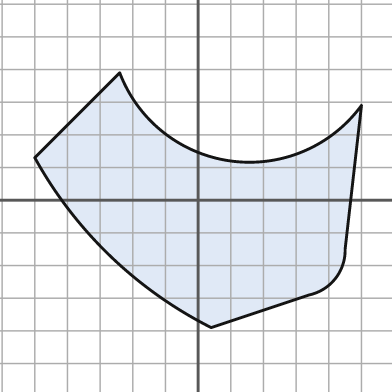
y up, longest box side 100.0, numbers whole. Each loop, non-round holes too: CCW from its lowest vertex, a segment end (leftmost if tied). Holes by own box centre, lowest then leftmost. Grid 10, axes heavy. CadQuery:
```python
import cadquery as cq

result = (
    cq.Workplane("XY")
    .moveTo(4.0, -39.0)
    .lineTo(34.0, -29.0)
    .threePointArc((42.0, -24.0), (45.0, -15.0))
    .lineTo(50.0, 29.0)
    .threePointArc((10.0, 12.0), (-24.0, 39.0))
    .lineTo(-50.0, 13.0)
    .threePointArc((-27.0, -17.0), (4.0, -39.0))
    .close()
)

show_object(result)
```